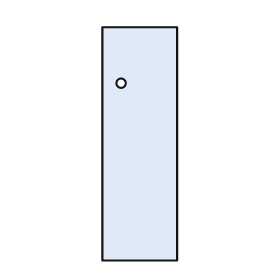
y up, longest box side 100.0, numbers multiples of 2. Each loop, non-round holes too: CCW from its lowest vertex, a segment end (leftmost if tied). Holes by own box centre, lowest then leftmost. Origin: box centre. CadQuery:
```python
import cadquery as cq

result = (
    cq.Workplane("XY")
    .moveTo(-16.0, -50.0)
    .lineTo(16.0, -50.0)
    .lineTo(16.0, 50.0)
    .lineTo(-16.0, 50.0)
    .close()
    .moveTo(-8.0, 26.0)
    .circle(2.0)
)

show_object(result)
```